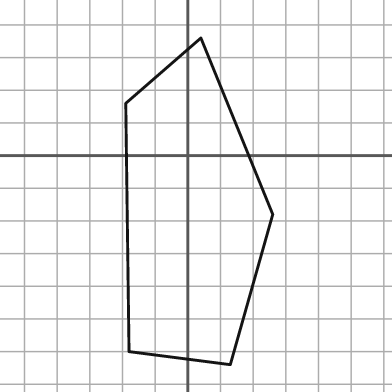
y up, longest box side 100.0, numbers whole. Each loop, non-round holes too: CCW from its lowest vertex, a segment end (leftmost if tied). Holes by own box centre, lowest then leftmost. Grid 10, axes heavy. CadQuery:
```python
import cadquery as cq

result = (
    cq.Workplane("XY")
    .moveTo(13.0, -64.0)
    .lineTo(26.0, -18.0)
    .lineTo(4.0, 36.0)
    .lineTo(-19.0, 16.0)
    .lineTo(-18.0, -60.0)
    .close()
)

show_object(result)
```